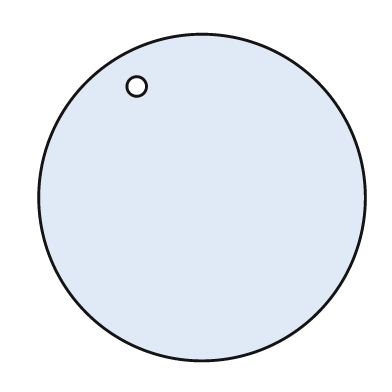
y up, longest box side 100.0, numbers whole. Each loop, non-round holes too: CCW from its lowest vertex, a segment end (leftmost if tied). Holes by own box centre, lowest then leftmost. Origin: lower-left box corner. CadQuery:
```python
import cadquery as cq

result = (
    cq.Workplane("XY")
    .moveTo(50.0, 50.0)
    .circle(50.0)
    .moveTo(30.0, 84.0)
    .circle(3.0)
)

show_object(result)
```